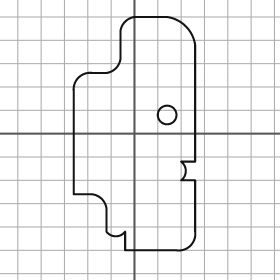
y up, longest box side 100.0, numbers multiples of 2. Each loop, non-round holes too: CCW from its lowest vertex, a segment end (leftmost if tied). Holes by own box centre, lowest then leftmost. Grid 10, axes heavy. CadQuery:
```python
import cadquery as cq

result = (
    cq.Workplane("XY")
    .moveTo(-4.0, -50.0)
    .lineTo(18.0, -50.0)
    .threePointArc((24.0, -48.0), (26.0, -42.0))
    .lineTo(26.0, -20.0)
    .lineTo(20.0, -20.0)
    .threePointArc((22.0, -16.0), (20.0, -12.0))
    .lineTo(26.0, -12.0)
    .lineTo(26.0, 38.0)
    .threePointArc((22.0, 46.0), (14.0, 50.0))
    .lineTo(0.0, 50.0)
    .threePointArc((-4.0, 48.0), (-6.0, 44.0))
    .lineTo(-6.0, 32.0)
    .threePointArc((-8.0, 28.0), (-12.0, 26.0))
    .lineTo(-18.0, 26.0)
    .threePointArc((-24.0, 24.0), (-26.0, 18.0))
    .lineTo(-26.0, -26.0)
    .lineTo(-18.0, -26.0)
    .threePointArc((-14.0, -28.0), (-12.0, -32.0))
    .lineTo(-12.0, -42.0)
    .threePointArc((-8.0, -44.0), (-4.0, -42.0))
    .close()
    .moveTo(14.0, 8.0)
    .circle(4.0)
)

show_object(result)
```